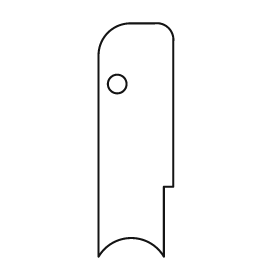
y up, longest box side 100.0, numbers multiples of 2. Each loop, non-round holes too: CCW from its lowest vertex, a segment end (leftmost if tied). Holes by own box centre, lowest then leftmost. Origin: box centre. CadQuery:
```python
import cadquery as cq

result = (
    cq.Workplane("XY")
    .moveTo(-16.0, -50.0)
    .threePointArc((-2.0, -42.0), (12.0, -50.0))
    .lineTo(12.0, -20.0)
    .lineTo(16.0, -20.0)
    .lineTo(16.0, 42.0)
    .threePointArc((14.0, 48.0), (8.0, 50.0))
    .lineTo(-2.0, 50.0)
    .threePointArc((-12.0, 46.0), (-16.0, 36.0))
    .close()
    .moveTo(-8.0, 24.0)
    .circle(4.0)
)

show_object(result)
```